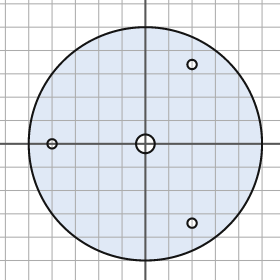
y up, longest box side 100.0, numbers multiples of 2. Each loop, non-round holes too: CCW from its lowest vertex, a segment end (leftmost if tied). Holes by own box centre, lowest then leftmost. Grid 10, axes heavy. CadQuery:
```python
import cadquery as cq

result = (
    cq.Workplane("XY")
    .moveTo(0.0, 0.0)
    .circle(50.0)
    .moveTo(20.0, -34.0)
    .circle(2.0)
    .moveTo(-40.0, 0.0)
    .circle(2.0)
    .moveTo(0.0, 0.0)
    .circle(4.0)
    .moveTo(20.0, 34.0)
    .circle(2.0)
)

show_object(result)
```